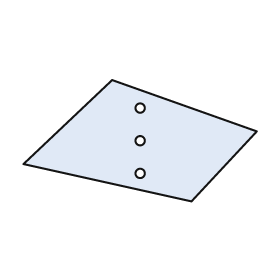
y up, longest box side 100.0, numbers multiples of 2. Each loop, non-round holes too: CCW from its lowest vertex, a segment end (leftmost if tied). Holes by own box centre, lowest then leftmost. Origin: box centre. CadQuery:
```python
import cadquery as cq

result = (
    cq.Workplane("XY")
    .moveTo(22.0, -26.0)
    .lineTo(50.0, 4.0)
    .lineTo(-12.0, 26.0)
    .lineTo(-50.0, -10.0)
    .close()
    .moveTo(0.0, -14.0)
    .circle(2.0)
    .moveTo(0.0, 0.0)
    .circle(2.0)
    .moveTo(0.0, 14.0)
    .circle(2.0)
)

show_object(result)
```